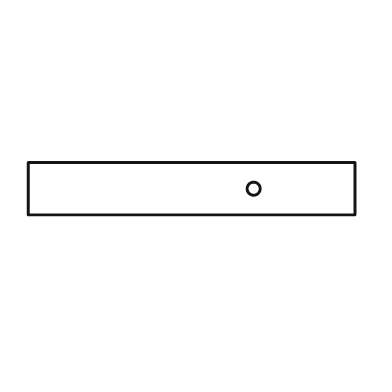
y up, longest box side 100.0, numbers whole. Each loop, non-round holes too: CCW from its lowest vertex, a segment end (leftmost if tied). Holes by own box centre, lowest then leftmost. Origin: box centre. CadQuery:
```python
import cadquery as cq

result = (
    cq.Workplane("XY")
    .moveTo(-50.0, -8.0)
    .lineTo(50.0, -8.0)
    .lineTo(50.0, 8.0)
    .lineTo(-50.0, 8.0)
    .close()
    .moveTo(19.0, 0.0)
    .circle(2.0)
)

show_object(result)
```